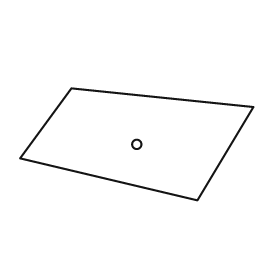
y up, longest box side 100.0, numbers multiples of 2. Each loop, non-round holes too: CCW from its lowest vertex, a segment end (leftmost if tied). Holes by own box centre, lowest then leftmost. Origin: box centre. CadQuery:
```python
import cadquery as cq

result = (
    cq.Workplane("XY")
    .moveTo(26.0, -24.0)
    .lineTo(50.0, 16.0)
    .lineTo(-28.0, 24.0)
    .lineTo(-50.0, -6.0)
    .close()
    .moveTo(0.0, 0.0)
    .circle(2.0)
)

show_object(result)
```